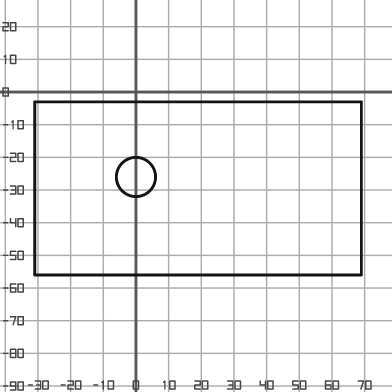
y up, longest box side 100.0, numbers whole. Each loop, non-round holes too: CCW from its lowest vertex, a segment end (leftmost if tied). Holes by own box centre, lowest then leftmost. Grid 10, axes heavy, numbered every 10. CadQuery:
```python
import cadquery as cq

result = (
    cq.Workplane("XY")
    .moveTo(-31.0, -56.0)
    .lineTo(69.0, -56.0)
    .lineTo(69.0, -3.0)
    .lineTo(-31.0, -3.0)
    .close()
    .moveTo(0.0, -26.0)
    .circle(6.0)
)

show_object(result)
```